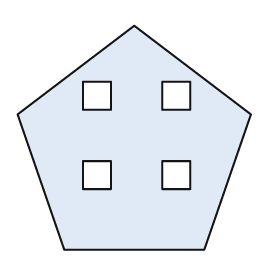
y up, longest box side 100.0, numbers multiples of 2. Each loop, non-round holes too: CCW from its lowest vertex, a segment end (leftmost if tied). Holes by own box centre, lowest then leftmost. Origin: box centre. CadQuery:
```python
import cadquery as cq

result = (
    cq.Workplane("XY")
    .moveTo(-30.0, -48.0)
    .lineTo(30.0, -48.0)
    .lineTo(50.0, 10.0)
    .lineTo(0.0, 48.0)
    .lineTo(-50.0, 10.0)
    .close()
    .moveTo(-22.0, -22.0)
    .lineTo(-10.0, -22.0)
    .lineTo(-10.0, -10.0)
    .lineTo(-22.0, -10.0)
    .close()
    .moveTo(12.0, -22.0)
    .lineTo(24.0, -22.0)
    .lineTo(24.0, -10.0)
    .lineTo(12.0, -10.0)
    .close()
    .moveTo(-22.0, 12.0)
    .lineTo(-10.0, 12.0)
    .lineTo(-10.0, 24.0)
    .lineTo(-22.0, 24.0)
    .close()
    .moveTo(12.0, 12.0)
    .lineTo(24.0, 12.0)
    .lineTo(24.0, 24.0)
    .lineTo(12.0, 24.0)
    .close()
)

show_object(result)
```